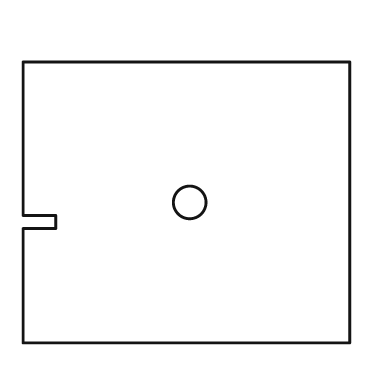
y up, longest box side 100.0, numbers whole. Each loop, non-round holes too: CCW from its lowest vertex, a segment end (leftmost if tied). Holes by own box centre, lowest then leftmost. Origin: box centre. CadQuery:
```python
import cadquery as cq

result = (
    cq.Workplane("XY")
    .moveTo(-50.0, -43.0)
    .lineTo(50.0, -43.0)
    .lineTo(50.0, 43.0)
    .lineTo(-50.0, 43.0)
    .lineTo(-50.0, -4.0)
    .lineTo(-40.0, -4.0)
    .lineTo(-40.0, -8.0)
    .lineTo(-50.0, -8.0)
    .close()
    .moveTo(1.0, 0.0)
    .circle(5.0)
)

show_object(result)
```